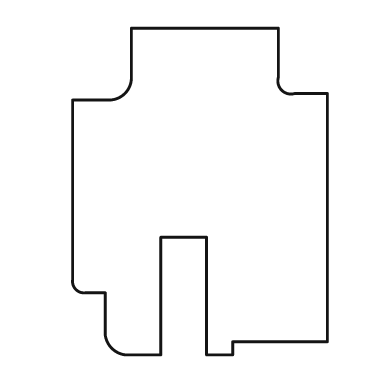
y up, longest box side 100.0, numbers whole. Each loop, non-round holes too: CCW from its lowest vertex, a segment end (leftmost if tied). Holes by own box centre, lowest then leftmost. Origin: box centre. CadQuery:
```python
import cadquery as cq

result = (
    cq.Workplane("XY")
    .moveTo(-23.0, -50.0)
    .lineTo(-12.0, -50.0)
    .lineTo(-12.0, -14.0)
    .lineTo(2.0, -14.0)
    .lineTo(2.0, -50.0)
    .lineTo(10.0, -50.0)
    .lineTo(10.0, -46.0)
    .lineTo(39.0, -46.0)
    .lineTo(39.0, 30.0)
    .lineTo(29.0, 30.0)
    .threePointArc((25.0, 31.0), (24.0, 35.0))
    .lineTo(24.0, 50.0)
    .lineTo(-21.0, 50.0)
    .lineTo(-21.0, 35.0)
    .threePointArc((-23.0, 30.0), (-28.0, 28.0))
    .lineTo(-39.0, 28.0)
    .lineTo(-39.0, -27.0)
    .threePointArc((-38.0, -30.0), (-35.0, -31.0))
    .lineTo(-29.0, -31.0)
    .lineTo(-29.0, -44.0)
    .threePointArc((-27.0, -48.0), (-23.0, -50.0))
    .close()
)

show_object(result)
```